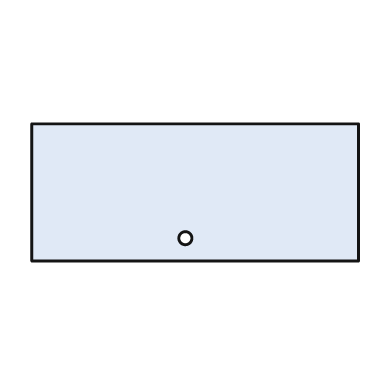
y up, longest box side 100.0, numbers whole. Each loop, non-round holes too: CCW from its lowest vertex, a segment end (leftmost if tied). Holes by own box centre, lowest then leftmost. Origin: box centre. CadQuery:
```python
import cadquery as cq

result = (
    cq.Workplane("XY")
    .moveTo(-50.0, -21.0)
    .lineTo(50.0, -21.0)
    .lineTo(50.0, 21.0)
    .lineTo(-50.0, 21.0)
    .close()
    .moveTo(-3.0, -14.0)
    .circle(2.0)
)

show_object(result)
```